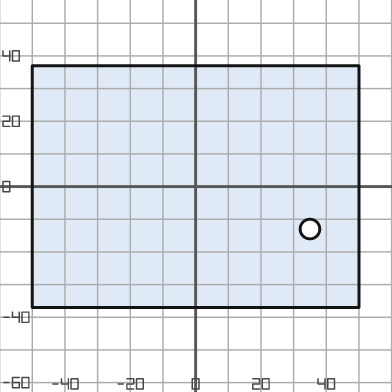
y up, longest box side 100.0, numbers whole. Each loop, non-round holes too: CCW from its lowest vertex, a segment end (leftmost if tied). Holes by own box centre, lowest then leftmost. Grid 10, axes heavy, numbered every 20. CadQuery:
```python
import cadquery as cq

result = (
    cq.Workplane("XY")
    .moveTo(-50.0, -37.0)
    .lineTo(50.0, -37.0)
    .lineTo(50.0, 37.0)
    .lineTo(-50.0, 37.0)
    .close()
    .moveTo(35.0, -13.0)
    .circle(3.0)
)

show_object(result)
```